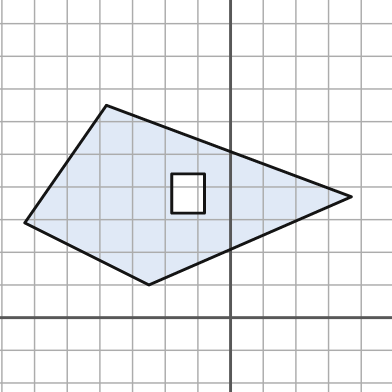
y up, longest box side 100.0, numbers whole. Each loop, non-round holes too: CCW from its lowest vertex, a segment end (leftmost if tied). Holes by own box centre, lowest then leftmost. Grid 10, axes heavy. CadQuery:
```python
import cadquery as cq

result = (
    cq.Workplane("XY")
    .moveTo(-25.0, 10.0)
    .lineTo(37.0, 37.0)
    .lineTo(-38.0, 65.0)
    .lineTo(-63.0, 29.0)
    .close()
    .moveTo(-18.0, 32.0)
    .lineTo(-8.0, 32.0)
    .lineTo(-8.0, 44.0)
    .lineTo(-18.0, 44.0)
    .close()
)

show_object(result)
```